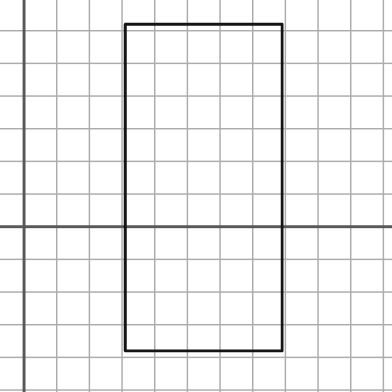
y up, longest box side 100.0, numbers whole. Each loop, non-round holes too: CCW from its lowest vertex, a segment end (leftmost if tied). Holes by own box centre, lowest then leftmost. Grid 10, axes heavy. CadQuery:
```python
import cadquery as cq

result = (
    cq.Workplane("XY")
    .moveTo(31.0, -38.0)
    .lineTo(79.0, -38.0)
    .lineTo(79.0, 62.0)
    .lineTo(31.0, 62.0)
    .close()
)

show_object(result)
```